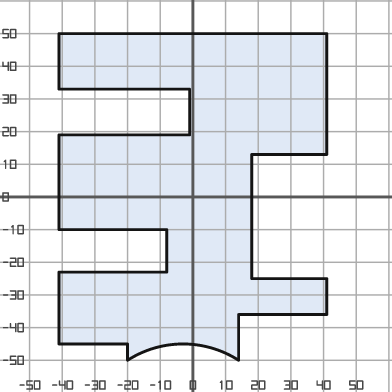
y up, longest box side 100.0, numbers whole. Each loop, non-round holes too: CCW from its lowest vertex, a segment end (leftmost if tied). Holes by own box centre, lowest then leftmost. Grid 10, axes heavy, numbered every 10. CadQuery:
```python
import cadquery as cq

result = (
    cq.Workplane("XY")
    .moveTo(-20.0, -50.0)
    .threePointArc((-3.0, -45.0), (14.0, -50.0))
    .lineTo(14.0, -36.0)
    .lineTo(41.0, -36.0)
    .lineTo(41.0, -25.0)
    .lineTo(18.0, -25.0)
    .lineTo(18.0, 13.0)
    .lineTo(41.0, 13.0)
    .lineTo(41.0, 50.0)
    .lineTo(-41.0, 50.0)
    .lineTo(-41.0, 33.0)
    .lineTo(-1.0, 33.0)
    .lineTo(-1.0, 19.0)
    .lineTo(-41.0, 19.0)
    .lineTo(-41.0, -10.0)
    .lineTo(-8.0, -10.0)
    .lineTo(-8.0, -23.0)
    .lineTo(-41.0, -23.0)
    .lineTo(-41.0, -45.0)
    .lineTo(-20.0, -45.0)
    .close()
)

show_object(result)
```